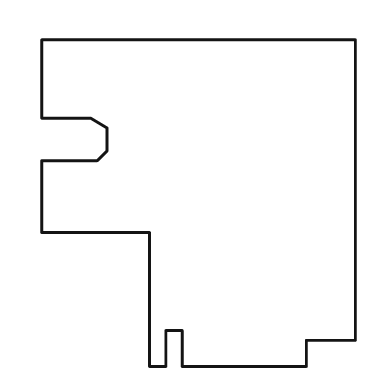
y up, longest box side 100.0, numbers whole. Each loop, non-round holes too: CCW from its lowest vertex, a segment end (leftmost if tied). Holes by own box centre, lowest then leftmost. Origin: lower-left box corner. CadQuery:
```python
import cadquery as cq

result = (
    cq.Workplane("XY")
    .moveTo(33.0, 0.0)
    .lineTo(38.0, 0.0)
    .lineTo(38.0, 11.0)
    .lineTo(43.0, 11.0)
    .lineTo(43.0, 0.0)
    .lineTo(81.0, 0.0)
    .lineTo(81.0, 8.0)
    .lineTo(96.0, 8.0)
    .lineTo(96.0, 100.0)
    .lineTo(0.0, 100.0)
    .lineTo(0.0, 76.0)
    .lineTo(15.0, 76.0)
    .lineTo(20.0, 73.0)
    .lineTo(20.0, 66.0)
    .lineTo(17.0, 63.0)
    .lineTo(0.0, 63.0)
    .lineTo(0.0, 41.0)
    .lineTo(33.0, 41.0)
    .close()
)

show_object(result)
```